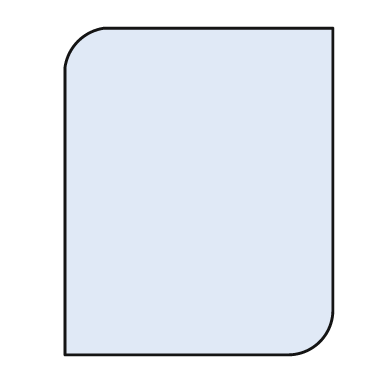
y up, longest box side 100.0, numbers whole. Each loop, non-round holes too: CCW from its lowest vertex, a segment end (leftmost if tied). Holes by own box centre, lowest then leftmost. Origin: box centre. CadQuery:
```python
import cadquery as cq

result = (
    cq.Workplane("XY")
    .moveTo(-41.0, -50.0)
    .lineTo(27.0, -50.0)
    .threePointArc((37.0, -46.0), (41.0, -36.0))
    .lineTo(41.0, 50.0)
    .lineTo(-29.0, 50.0)
    .threePointArc((-37.0, 46.0), (-41.0, 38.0))
    .close()
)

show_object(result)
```